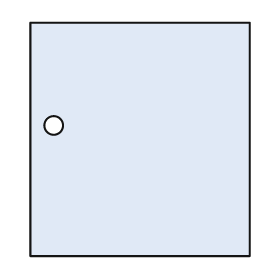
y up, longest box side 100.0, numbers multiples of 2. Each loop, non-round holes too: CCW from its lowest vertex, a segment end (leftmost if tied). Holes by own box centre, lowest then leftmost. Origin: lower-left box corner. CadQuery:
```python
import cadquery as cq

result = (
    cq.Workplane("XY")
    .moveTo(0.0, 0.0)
    .lineTo(94.0, 0.0)
    .lineTo(94.0, 100.0)
    .lineTo(0.0, 100.0)
    .close()
    .moveTo(10.0, 56.0)
    .circle(4.0)
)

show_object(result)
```